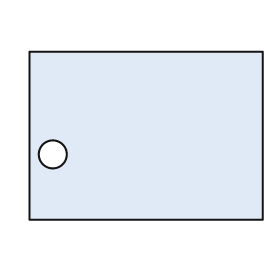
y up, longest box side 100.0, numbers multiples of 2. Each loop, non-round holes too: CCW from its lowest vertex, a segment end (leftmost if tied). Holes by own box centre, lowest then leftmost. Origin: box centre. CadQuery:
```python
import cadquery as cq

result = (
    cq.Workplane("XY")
    .moveTo(-50.0, -36.0)
    .lineTo(50.0, -36.0)
    .lineTo(50.0, 36.0)
    .lineTo(-50.0, 36.0)
    .close()
    .moveTo(-40.0, -8.0)
    .circle(6.0)
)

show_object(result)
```